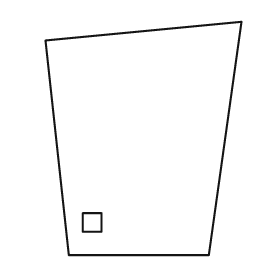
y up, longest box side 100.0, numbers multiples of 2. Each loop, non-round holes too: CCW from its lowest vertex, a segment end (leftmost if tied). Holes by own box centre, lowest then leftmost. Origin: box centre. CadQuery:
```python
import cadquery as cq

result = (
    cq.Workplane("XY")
    .moveTo(-32.0, -50.0)
    .lineTo(28.0, -50.0)
    .lineTo(42.0, 50.0)
    .lineTo(-42.0, 42.0)
    .close()
    .moveTo(-26.0, -40.0)
    .lineTo(-18.0, -40.0)
    .lineTo(-18.0, -32.0)
    .lineTo(-26.0, -32.0)
    .close()
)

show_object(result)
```